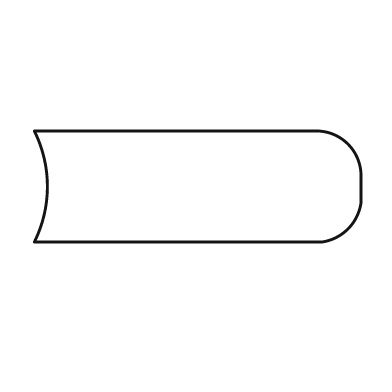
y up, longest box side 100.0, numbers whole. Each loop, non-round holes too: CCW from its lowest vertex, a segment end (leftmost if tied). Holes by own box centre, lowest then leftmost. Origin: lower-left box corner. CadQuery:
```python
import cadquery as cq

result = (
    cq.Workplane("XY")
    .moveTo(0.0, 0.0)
    .lineTo(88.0, 0.0)
    .threePointArc((96.0, 4.0), (100.0, 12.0))
    .lineTo(100.0, 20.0)
    .threePointArc((96.0, 30.0), (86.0, 34.0))
    .lineTo(0.0, 34.0)
    .threePointArc((4.0, 17.0), (0.0, 0.0))
    .close()
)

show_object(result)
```